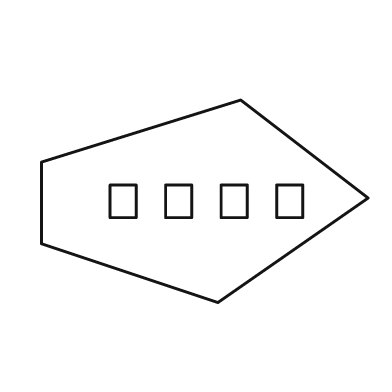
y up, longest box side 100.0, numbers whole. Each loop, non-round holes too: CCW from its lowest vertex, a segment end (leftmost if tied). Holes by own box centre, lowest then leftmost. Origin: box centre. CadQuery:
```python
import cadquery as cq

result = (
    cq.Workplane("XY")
    .moveTo(4.0, -31.0)
    .lineTo(50.0, 1.0)
    .lineTo(11.0, 31.0)
    .lineTo(-50.0, 12.0)
    .lineTo(-50.0, -13.0)
    .close()
    .moveTo(-29.0, -5.0)
    .lineTo(-21.0, -5.0)
    .lineTo(-21.0, 5.0)
    .lineTo(-29.0, 5.0)
    .close()
    .moveTo(-12.0, -5.0)
    .lineTo(-4.0, -5.0)
    .lineTo(-4.0, 5.0)
    .lineTo(-12.0, 5.0)
    .close()
    .moveTo(5.0, -5.0)
    .lineTo(13.0, -5.0)
    .lineTo(13.0, 5.0)
    .lineTo(5.0, 5.0)
    .close()
    .moveTo(22.0, -5.0)
    .lineTo(30.0, -5.0)
    .lineTo(30.0, 5.0)
    .lineTo(22.0, 5.0)
    .close()
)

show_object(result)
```